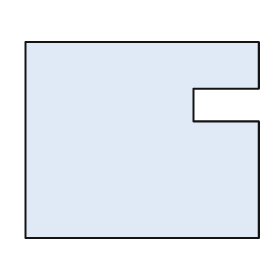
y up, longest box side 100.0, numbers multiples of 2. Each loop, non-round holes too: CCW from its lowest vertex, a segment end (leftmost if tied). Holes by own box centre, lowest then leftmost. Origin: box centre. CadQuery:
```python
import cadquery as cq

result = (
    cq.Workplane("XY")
    .moveTo(-50.0, -42.0)
    .lineTo(50.0, -42.0)
    .lineTo(50.0, 8.0)
    .lineTo(22.0, 8.0)
    .lineTo(22.0, 22.0)
    .lineTo(50.0, 22.0)
    .lineTo(50.0, 42.0)
    .lineTo(-50.0, 42.0)
    .close()
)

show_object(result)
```